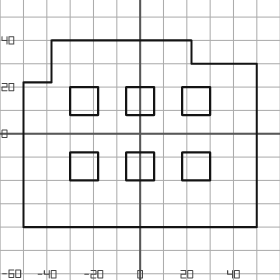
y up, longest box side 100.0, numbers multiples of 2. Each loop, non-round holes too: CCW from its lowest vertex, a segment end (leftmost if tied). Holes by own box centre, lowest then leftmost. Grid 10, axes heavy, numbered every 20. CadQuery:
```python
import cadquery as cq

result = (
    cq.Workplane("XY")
    .moveTo(-50.0, -40.0)
    .lineTo(50.0, -40.0)
    .lineTo(50.0, 30.0)
    .lineTo(22.0, 30.0)
    .lineTo(22.0, 40.0)
    .lineTo(-38.0, 40.0)
    .lineTo(-38.0, 22.0)
    .lineTo(-50.0, 22.0)
    .close()
    .moveTo(-30.0, -20.0)
    .lineTo(-18.0, -20.0)
    .lineTo(-18.0, -8.0)
    .lineTo(-30.0, -8.0)
    .close()
    .moveTo(-6.0, -20.0)
    .lineTo(6.0, -20.0)
    .lineTo(6.0, -8.0)
    .lineTo(-6.0, -8.0)
    .close()
    .moveTo(18.0, -20.0)
    .lineTo(30.0, -20.0)
    .lineTo(30.0, -8.0)
    .lineTo(18.0, -8.0)
    .close()
    .moveTo(-30.0, 8.0)
    .lineTo(-18.0, 8.0)
    .lineTo(-18.0, 20.0)
    .lineTo(-30.0, 20.0)
    .close()
    .moveTo(-6.0, 8.0)
    .lineTo(6.0, 8.0)
    .lineTo(6.0, 20.0)
    .lineTo(-6.0, 20.0)
    .close()
    .moveTo(18.0, 8.0)
    .lineTo(30.0, 8.0)
    .lineTo(30.0, 20.0)
    .lineTo(18.0, 20.0)
    .close()
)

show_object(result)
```